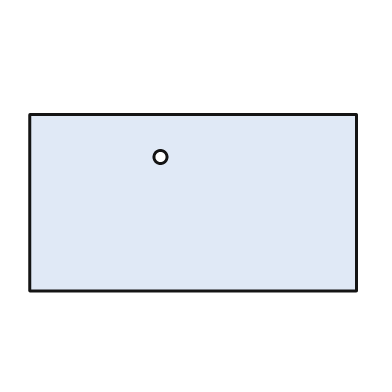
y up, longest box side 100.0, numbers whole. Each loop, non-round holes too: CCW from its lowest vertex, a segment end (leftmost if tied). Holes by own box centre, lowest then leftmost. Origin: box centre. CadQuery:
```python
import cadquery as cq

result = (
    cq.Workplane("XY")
    .moveTo(-50.0, -27.0)
    .lineTo(50.0, -27.0)
    .lineTo(50.0, 27.0)
    .lineTo(-50.0, 27.0)
    .close()
    .moveTo(-10.0, 14.0)
    .circle(2.0)
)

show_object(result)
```